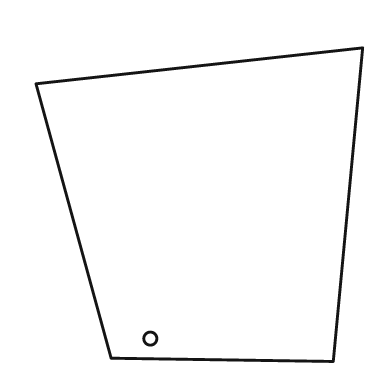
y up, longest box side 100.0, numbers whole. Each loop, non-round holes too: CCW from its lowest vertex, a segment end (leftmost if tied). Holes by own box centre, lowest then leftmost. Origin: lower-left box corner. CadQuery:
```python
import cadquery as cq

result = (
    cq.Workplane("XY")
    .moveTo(91.0, 0.0)
    .lineTo(100.0, 96.0)
    .lineTo(0.0, 85.0)
    .lineTo(23.0, 1.0)
    .close()
    .moveTo(35.0, 7.0)
    .circle(2.0)
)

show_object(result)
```